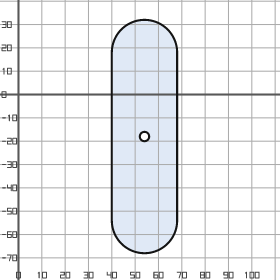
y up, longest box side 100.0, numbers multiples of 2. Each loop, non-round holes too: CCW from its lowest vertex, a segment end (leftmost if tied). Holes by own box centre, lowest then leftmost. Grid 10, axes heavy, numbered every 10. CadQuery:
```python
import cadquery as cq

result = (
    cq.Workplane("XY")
    .moveTo(40.0, -54.0)
    .threePointArc((54.0, -68.0), (68.0, -54.0))
    .lineTo(68.0, 18.0)
    .threePointArc((54.0, 32.0), (40.0, 18.0))
    .close()
    .moveTo(54.0, -18.0)
    .circle(2.0)
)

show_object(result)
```